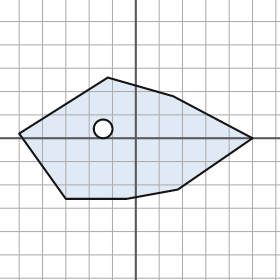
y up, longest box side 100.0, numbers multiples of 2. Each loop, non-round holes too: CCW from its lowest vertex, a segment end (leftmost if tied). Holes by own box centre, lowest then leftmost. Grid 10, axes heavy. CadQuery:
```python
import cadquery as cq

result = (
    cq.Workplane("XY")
    .moveTo(-30.0, -26.0)
    .lineTo(-4.0, -26.0)
    .lineTo(18.0, -22.0)
    .lineTo(50.0, 0.0)
    .lineTo(16.0, 18.0)
    .lineTo(-12.0, 26.0)
    .lineTo(-50.0, 2.0)
    .close()
    .moveTo(-14.0, 4.0)
    .circle(4.0)
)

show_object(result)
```